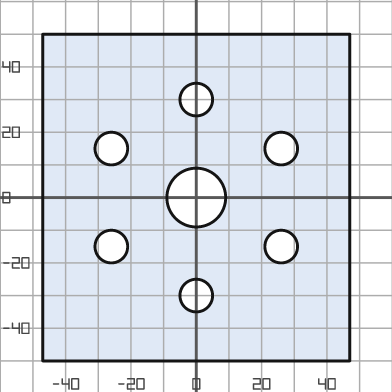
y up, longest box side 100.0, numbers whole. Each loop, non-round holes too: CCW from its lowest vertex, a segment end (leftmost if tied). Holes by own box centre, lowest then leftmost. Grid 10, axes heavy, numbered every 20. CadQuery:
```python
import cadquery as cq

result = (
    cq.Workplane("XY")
    .moveTo(-47.0, -50.0)
    .lineTo(47.0, -50.0)
    .lineTo(47.0, 50.0)
    .lineTo(-47.0, 50.0)
    .close()
    .moveTo(0.0, -30.0)
    .circle(5.0)
    .moveTo(-26.0, -15.0)
    .circle(5.0)
    .moveTo(26.0, -15.0)
    .circle(5.0)
    .moveTo(0.0, 0.0)
    .circle(9.0)
    .moveTo(-26.0, 15.0)
    .circle(5.0)
    .moveTo(26.0, 15.0)
    .circle(5.0)
    .moveTo(0.0, 30.0)
    .circle(5.0)
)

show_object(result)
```